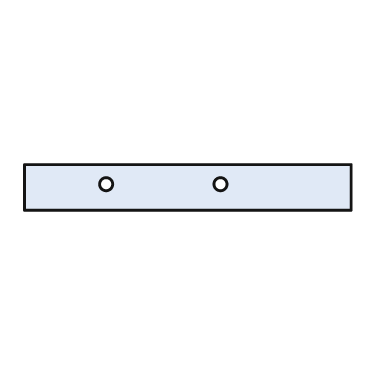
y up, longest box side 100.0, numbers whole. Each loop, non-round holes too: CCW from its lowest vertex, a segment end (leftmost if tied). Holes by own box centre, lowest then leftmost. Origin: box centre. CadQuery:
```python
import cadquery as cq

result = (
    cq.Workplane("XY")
    .moveTo(-50.0, -7.0)
    .lineTo(50.0, -7.0)
    .lineTo(50.0, 7.0)
    .lineTo(-50.0, 7.0)
    .close()
    .moveTo(-25.0, 1.0)
    .circle(2.0)
    .moveTo(10.0, 1.0)
    .circle(2.0)
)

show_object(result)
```